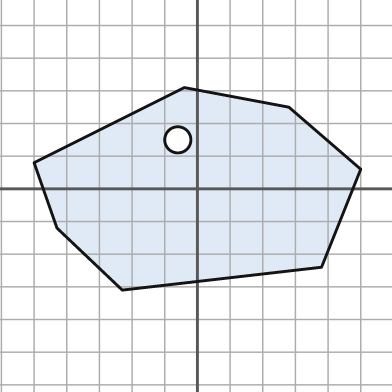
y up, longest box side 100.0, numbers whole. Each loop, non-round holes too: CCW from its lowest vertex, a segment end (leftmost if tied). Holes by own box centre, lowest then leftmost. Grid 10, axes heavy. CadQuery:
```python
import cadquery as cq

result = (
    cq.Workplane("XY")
    .moveTo(-23.0, -31.0)
    .lineTo(38.0, -24.0)
    .lineTo(50.0, 6.0)
    .lineTo(28.0, 25.0)
    .lineTo(-4.0, 31.0)
    .lineTo(-50.0, 8.0)
    .lineTo(-43.0, -12.0)
    .close()
    .moveTo(-6.0, 15.0)
    .circle(4.0)
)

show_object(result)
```